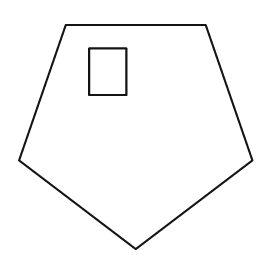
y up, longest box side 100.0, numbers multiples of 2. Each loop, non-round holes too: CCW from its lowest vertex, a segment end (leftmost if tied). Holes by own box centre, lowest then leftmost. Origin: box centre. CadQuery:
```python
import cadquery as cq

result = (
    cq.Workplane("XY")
    .moveTo(0.0, -48.0)
    .lineTo(50.0, -10.0)
    .lineTo(30.0, 48.0)
    .lineTo(-30.0, 48.0)
    .lineTo(-50.0, -10.0)
    .close()
    .moveTo(-20.0, 18.0)
    .lineTo(-4.0, 18.0)
    .lineTo(-4.0, 38.0)
    .lineTo(-20.0, 38.0)
    .close()
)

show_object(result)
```